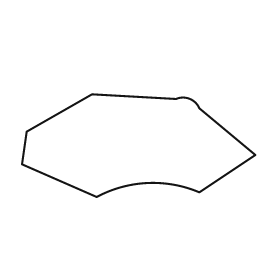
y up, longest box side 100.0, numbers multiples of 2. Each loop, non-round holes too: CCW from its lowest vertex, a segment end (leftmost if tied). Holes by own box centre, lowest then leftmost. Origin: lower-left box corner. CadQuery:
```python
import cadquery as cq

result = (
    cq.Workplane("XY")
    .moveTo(32.0, 0.0)
    .threePointArc((54.0, 6.0), (76.0, 2.0))
    .lineTo(100.0, 18.0)
    .lineTo(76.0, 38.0)
    .threePointArc((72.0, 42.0), (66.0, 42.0))
    .lineTo(30.0, 44.0)
    .lineTo(2.0, 28.0)
    .lineTo(0.0, 14.0)
    .close()
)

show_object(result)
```